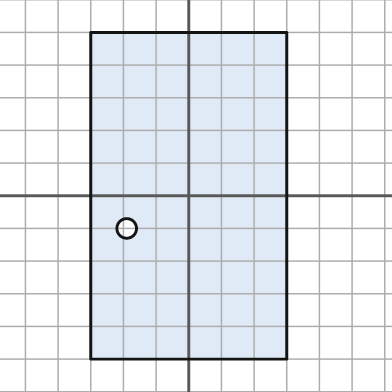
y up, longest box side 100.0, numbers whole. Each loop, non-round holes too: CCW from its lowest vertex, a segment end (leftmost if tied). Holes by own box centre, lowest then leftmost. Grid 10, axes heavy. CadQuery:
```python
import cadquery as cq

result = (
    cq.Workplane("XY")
    .moveTo(-30.0, -50.0)
    .lineTo(30.0, -50.0)
    .lineTo(30.0, 50.0)
    .lineTo(-30.0, 50.0)
    .close()
    .moveTo(-19.0, -10.0)
    .circle(3.0)
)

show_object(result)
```